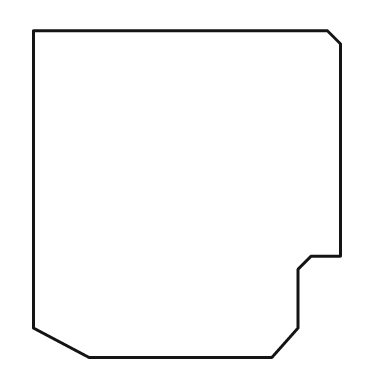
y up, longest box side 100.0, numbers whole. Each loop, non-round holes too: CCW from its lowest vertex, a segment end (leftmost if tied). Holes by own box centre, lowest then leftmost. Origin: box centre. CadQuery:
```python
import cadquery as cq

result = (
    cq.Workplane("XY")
    .moveTo(-30.0, -50.0)
    .lineTo(26.0, -50.0)
    .lineTo(34.0, -41.0)
    .lineTo(34.0, -23.0)
    .lineTo(38.0, -19.0)
    .lineTo(47.0, -19.0)
    .lineTo(47.0, 46.0)
    .lineTo(43.0, 50.0)
    .lineTo(-47.0, 50.0)
    .lineTo(-47.0, -41.0)
    .close()
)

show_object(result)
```